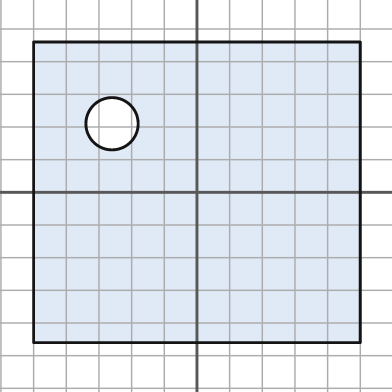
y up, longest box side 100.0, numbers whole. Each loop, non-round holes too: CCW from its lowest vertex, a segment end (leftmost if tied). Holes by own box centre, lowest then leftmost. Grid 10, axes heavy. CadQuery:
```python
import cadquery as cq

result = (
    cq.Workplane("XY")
    .moveTo(-50.0, -46.0)
    .lineTo(50.0, -46.0)
    .lineTo(50.0, 46.0)
    .lineTo(-50.0, 46.0)
    .close()
    .moveTo(-26.0, 21.0)
    .circle(8.0)
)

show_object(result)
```